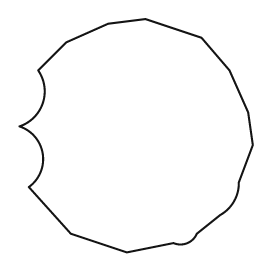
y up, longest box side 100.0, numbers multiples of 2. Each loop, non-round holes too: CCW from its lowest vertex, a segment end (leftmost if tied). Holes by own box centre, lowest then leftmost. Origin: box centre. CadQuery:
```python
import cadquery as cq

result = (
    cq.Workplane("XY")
    .moveTo(-4.0, -50.0)
    .lineTo(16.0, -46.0)
    .threePointArc((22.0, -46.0), (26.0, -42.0))
    .lineTo(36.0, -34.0)
    .threePointArc((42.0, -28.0), (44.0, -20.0))
    .lineTo(50.0, -4.0)
    .lineTo(48.0, 10.0)
    .lineTo(40.0, 28.0)
    .lineTo(28.0, 42.0)
    .lineTo(4.0, 50.0)
    .lineTo(-12.0, 48.0)
    .lineTo(-30.0, 40.0)
    .lineTo(-42.0, 28.0)
    .threePointArc((-40.0, 14.0), (-50.0, 4.0))
    .threePointArc((-40.0, -8.0), (-46.0, -22.0))
    .lineTo(-28.0, -42.0)
    .close()
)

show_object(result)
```